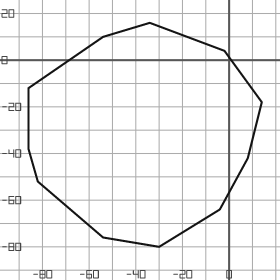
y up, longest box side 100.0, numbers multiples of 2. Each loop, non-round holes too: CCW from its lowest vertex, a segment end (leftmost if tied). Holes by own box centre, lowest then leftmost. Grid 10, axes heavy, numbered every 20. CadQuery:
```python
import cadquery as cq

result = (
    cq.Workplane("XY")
    .moveTo(-30.0, -80.0)
    .lineTo(-4.0, -64.0)
    .lineTo(8.0, -42.0)
    .lineTo(14.0, -18.0)
    .lineTo(-2.0, 4.0)
    .lineTo(-34.0, 16.0)
    .lineTo(-54.0, 10.0)
    .lineTo(-86.0, -12.0)
    .lineTo(-86.0, -38.0)
    .lineTo(-82.0, -52.0)
    .lineTo(-54.0, -76.0)
    .close()
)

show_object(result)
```